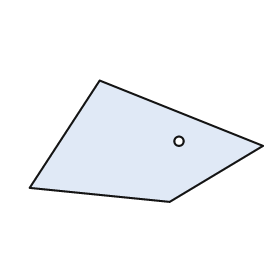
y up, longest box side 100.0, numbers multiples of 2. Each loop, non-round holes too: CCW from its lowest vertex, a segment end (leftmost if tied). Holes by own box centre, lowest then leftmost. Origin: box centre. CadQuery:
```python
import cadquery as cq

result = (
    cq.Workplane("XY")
    .moveTo(10.0, -26.0)
    .lineTo(50.0, -2.0)
    .lineTo(-20.0, 26.0)
    .lineTo(-50.0, -20.0)
    .close()
    .moveTo(14.0, 0.0)
    .circle(2.0)
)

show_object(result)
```